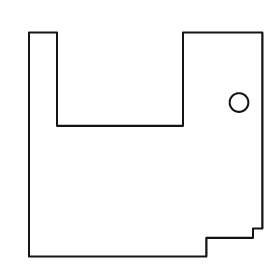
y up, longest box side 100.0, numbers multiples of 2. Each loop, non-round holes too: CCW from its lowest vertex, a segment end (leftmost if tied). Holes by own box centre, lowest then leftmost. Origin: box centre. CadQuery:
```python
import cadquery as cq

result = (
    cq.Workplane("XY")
    .moveTo(-50.0, -48.0)
    .lineTo(26.0, -48.0)
    .lineTo(26.0, -40.0)
    .lineTo(46.0, -40.0)
    .lineTo(46.0, -36.0)
    .lineTo(50.0, -36.0)
    .lineTo(50.0, 48.0)
    .lineTo(16.0, 48.0)
    .lineTo(16.0, 8.0)
    .lineTo(-38.0, 8.0)
    .lineTo(-38.0, 48.0)
    .lineTo(-50.0, 48.0)
    .close()
    .moveTo(40.0, 18.0)
    .circle(4.0)
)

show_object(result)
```